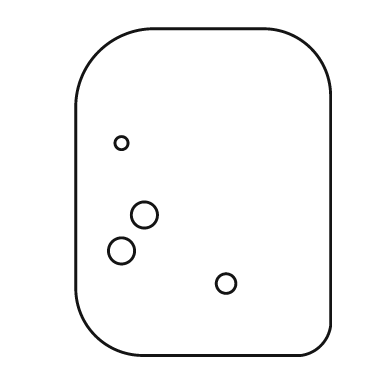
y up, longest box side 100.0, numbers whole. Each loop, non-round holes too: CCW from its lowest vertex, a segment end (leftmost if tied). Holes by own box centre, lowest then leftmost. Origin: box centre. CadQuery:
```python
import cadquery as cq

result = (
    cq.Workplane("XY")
    .moveTo(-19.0, -50.0)
    .lineTo(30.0, -50.0)
    .threePointArc((36.0, -47.0), (39.0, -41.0))
    .lineTo(39.0, 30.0)
    .threePointArc((33.0, 44.0), (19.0, 50.0))
    .lineTo(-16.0, 50.0)
    .threePointArc((-32.0, 43.0), (-39.0, 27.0))
    .lineTo(-39.0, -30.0)
    .threePointArc((-33.0, -44.0), (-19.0, -50.0))
    .close()
    .moveTo(7.0, -28.0)
    .circle(3.0)
    .moveTo(-25.0, -18.0)
    .circle(4.0)
    .moveTo(-18.0, -7.0)
    .circle(4.0)
    .moveTo(-25.0, 15.0)
    .circle(2.0)
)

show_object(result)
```